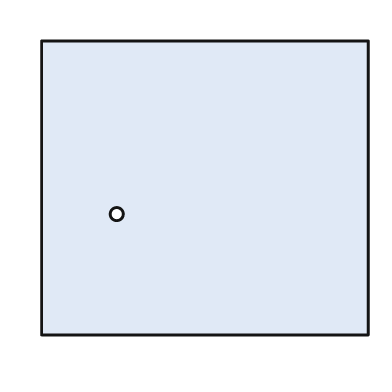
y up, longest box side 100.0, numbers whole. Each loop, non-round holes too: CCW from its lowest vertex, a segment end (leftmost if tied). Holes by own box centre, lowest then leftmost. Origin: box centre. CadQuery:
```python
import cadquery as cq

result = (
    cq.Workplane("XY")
    .moveTo(-50.0, -45.0)
    .lineTo(50.0, -45.0)
    .lineTo(50.0, 45.0)
    .lineTo(-50.0, 45.0)
    .close()
    .moveTo(-27.0, -8.0)
    .circle(2.0)
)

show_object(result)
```